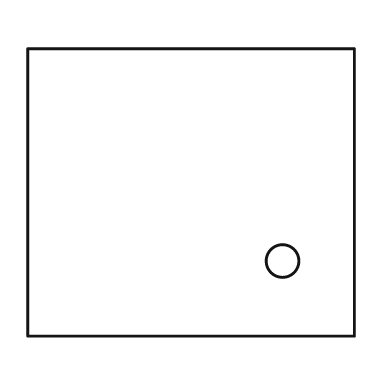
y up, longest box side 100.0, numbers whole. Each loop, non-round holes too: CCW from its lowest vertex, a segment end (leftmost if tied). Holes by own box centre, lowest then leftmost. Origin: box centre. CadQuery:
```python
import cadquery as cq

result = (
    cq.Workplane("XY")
    .moveTo(-50.0, -44.0)
    .lineTo(50.0, -44.0)
    .lineTo(50.0, 44.0)
    .lineTo(-50.0, 44.0)
    .close()
    .moveTo(28.0, -21.0)
    .circle(5.0)
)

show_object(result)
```